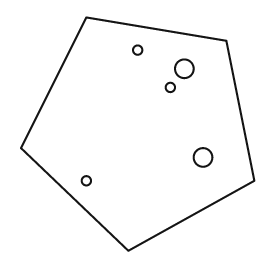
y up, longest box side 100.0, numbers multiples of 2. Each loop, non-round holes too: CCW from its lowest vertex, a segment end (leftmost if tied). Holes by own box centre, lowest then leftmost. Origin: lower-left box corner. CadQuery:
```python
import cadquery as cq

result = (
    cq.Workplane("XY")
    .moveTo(46.0, 0.0)
    .lineTo(100.0, 30.0)
    .lineTo(88.0, 90.0)
    .lineTo(28.0, 100.0)
    .lineTo(0.0, 44.0)
    .close()
    .moveTo(28.0, 30.0)
    .circle(2.0)
    .moveTo(78.0, 40.0)
    .circle(4.0)
    .moveTo(64.0, 70.0)
    .circle(2.0)
    .moveTo(70.0, 78.0)
    .circle(4.0)
    .moveTo(50.0, 86.0)
    .circle(2.0)
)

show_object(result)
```